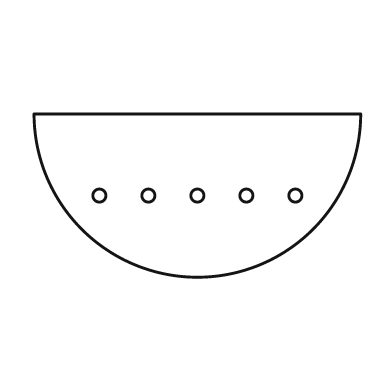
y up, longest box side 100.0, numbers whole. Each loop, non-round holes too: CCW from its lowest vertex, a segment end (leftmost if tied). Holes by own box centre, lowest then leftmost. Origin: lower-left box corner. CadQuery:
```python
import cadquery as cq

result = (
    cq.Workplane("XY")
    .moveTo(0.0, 50.0)
    .threePointArc((50.0, 0.0), (100.0, 50.0))
    .close()
    .moveTo(20.0, 25.0)
    .circle(2.0)
    .moveTo(35.0, 25.0)
    .circle(2.0)
    .moveTo(50.0, 25.0)
    .circle(2.0)
    .moveTo(65.0, 25.0)
    .circle(2.0)
    .moveTo(80.0, 25.0)
    .circle(2.0)
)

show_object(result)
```